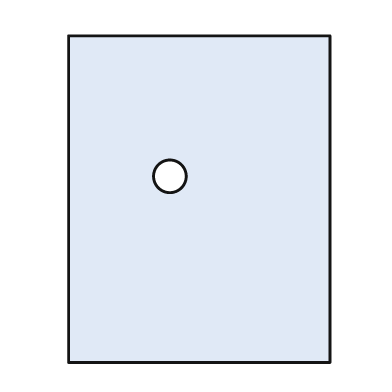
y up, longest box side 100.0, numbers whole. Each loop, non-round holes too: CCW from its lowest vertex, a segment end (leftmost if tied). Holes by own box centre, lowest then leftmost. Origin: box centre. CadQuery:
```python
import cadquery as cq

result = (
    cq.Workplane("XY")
    .moveTo(-40.0, -50.0)
    .lineTo(40.0, -50.0)
    .lineTo(40.0, 50.0)
    .lineTo(-40.0, 50.0)
    .close()
    .moveTo(-9.0, 7.0)
    .circle(5.0)
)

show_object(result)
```